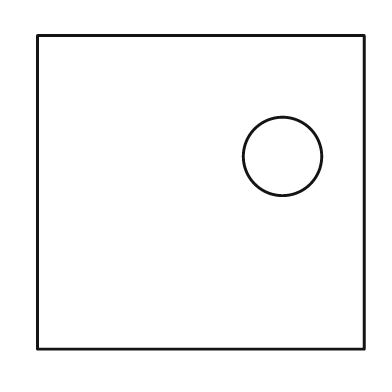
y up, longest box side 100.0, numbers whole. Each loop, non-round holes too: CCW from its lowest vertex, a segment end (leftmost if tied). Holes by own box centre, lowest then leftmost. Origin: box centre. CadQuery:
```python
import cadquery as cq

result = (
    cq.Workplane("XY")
    .moveTo(-50.0, -48.0)
    .lineTo(50.0, -48.0)
    .lineTo(50.0, 48.0)
    .lineTo(-50.0, 48.0)
    .close()
    .moveTo(25.0, 11.0)
    .circle(12.0)
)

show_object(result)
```